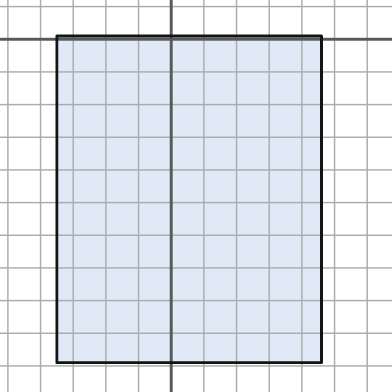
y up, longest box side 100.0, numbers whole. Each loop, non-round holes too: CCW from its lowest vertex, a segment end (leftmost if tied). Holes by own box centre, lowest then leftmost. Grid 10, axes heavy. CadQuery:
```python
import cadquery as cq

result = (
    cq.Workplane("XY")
    .moveTo(-35.0, -99.0)
    .lineTo(46.0, -99.0)
    .lineTo(46.0, 1.0)
    .lineTo(-35.0, 1.0)
    .close()
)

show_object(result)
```